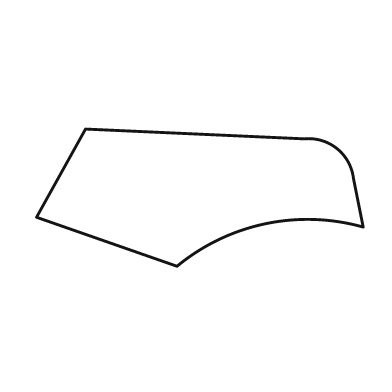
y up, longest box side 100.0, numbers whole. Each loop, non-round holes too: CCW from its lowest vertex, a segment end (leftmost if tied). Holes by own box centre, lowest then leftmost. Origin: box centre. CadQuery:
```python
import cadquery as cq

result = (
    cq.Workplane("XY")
    .moveTo(-7.0, -21.0)
    .threePointArc((20.0, -8.0), (50.0, -9.0))
    .lineTo(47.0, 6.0)
    .threePointArc((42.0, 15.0), (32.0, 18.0))
    .lineTo(-35.0, 21.0)
    .lineTo(-50.0, -6.0)
    .close()
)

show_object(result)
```